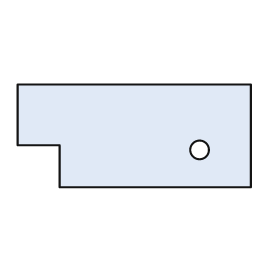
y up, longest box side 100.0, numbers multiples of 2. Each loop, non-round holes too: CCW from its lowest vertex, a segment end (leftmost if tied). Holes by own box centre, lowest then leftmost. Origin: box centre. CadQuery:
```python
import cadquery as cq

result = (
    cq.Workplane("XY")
    .moveTo(-32.0, -22.0)
    .lineTo(50.0, -22.0)
    .lineTo(50.0, 22.0)
    .lineTo(-50.0, 22.0)
    .lineTo(-50.0, -4.0)
    .lineTo(-32.0, -4.0)
    .close()
    .moveTo(28.0, -6.0)
    .circle(4.0)
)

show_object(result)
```